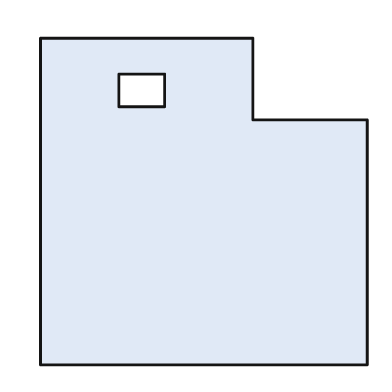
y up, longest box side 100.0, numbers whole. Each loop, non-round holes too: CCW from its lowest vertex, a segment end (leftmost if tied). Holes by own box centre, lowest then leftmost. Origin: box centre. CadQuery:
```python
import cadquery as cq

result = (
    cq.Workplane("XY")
    .moveTo(-50.0, -50.0)
    .lineTo(50.0, -50.0)
    .lineTo(50.0, 25.0)
    .lineTo(15.0, 25.0)
    .lineTo(15.0, 50.0)
    .lineTo(-50.0, 50.0)
    .close()
    .moveTo(-26.0, 29.0)
    .lineTo(-12.0, 29.0)
    .lineTo(-12.0, 39.0)
    .lineTo(-26.0, 39.0)
    .close()
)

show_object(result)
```